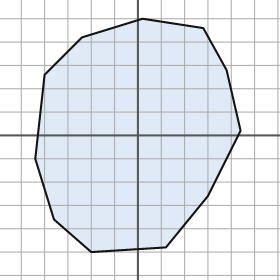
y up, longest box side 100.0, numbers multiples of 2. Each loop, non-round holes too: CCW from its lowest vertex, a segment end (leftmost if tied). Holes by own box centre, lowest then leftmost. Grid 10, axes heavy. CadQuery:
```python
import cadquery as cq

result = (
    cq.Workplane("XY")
    .moveTo(-20.0, -50.0)
    .lineTo(12.0, -48.0)
    .lineTo(30.0, -26.0)
    .lineTo(44.0, 2.0)
    .lineTo(38.0, 28.0)
    .lineTo(28.0, 46.0)
    .lineTo(2.0, 50.0)
    .lineTo(-24.0, 42.0)
    .lineTo(-40.0, 26.0)
    .lineTo(-44.0, -10.0)
    .lineTo(-36.0, -36.0)
    .close()
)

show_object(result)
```